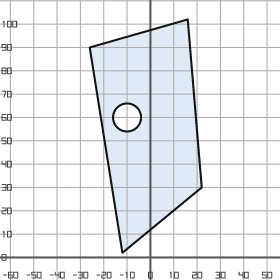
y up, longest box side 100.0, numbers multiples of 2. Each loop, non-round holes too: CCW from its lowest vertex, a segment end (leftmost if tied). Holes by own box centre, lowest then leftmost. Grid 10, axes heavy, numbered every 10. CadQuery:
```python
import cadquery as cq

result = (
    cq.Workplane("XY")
    .moveTo(-12.0, 2.0)
    .lineTo(22.0, 30.0)
    .lineTo(16.0, 102.0)
    .lineTo(-26.0, 90.0)
    .close()
    .moveTo(-10.0, 60.0)
    .circle(6.0)
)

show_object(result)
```